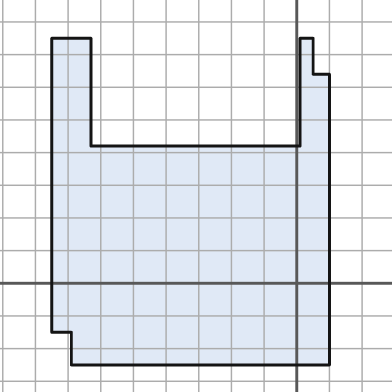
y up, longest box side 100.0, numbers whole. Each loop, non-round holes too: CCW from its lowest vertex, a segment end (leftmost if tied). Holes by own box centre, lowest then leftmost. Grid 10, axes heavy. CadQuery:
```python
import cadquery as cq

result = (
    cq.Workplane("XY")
    .moveTo(-69.0, -25.0)
    .lineTo(10.0, -25.0)
    .lineTo(10.0, 64.0)
    .lineTo(5.0, 64.0)
    .lineTo(5.0, 75.0)
    .lineTo(1.0, 75.0)
    .lineTo(1.0, 42.0)
    .lineTo(-63.0, 42.0)
    .lineTo(-63.0, 75.0)
    .lineTo(-75.0, 75.0)
    .lineTo(-75.0, -15.0)
    .lineTo(-69.0, -15.0)
    .close()
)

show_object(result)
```